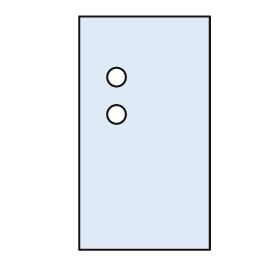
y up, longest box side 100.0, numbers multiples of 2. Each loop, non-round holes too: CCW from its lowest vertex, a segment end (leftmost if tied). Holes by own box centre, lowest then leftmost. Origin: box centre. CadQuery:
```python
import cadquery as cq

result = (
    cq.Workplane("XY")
    .moveTo(-28.0, -50.0)
    .lineTo(28.0, -50.0)
    .lineTo(28.0, 50.0)
    .lineTo(-28.0, 50.0)
    .close()
    .moveTo(-12.0, 8.0)
    .circle(4.0)
    .moveTo(-12.0, 24.0)
    .circle(4.0)
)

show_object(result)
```